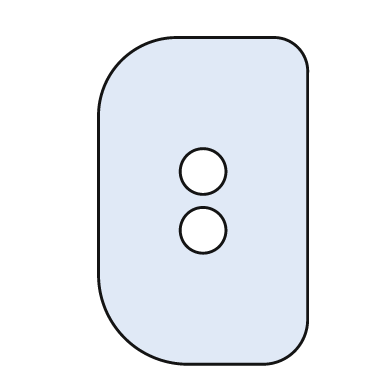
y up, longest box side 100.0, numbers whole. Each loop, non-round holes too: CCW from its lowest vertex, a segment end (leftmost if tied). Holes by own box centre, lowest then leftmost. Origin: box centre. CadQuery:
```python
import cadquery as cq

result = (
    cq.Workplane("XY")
    .moveTo(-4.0, -50.0)
    .lineTo(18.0, -50.0)
    .threePointArc((28.0, -46.0), (32.0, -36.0))
    .lineTo(32.0, 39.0)
    .threePointArc((29.0, 47.0), (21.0, 50.0))
    .lineTo(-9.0, 50.0)
    .threePointArc((-25.0, 43.0), (-32.0, 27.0))
    .lineTo(-32.0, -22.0)
    .threePointArc((-24.0, -42.0), (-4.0, -50.0))
    .close()
    .moveTo(0.0, -9.0)
    .circle(7.0)
    .moveTo(0.0, 9.0)
    .circle(7.0)
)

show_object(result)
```